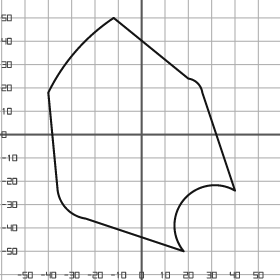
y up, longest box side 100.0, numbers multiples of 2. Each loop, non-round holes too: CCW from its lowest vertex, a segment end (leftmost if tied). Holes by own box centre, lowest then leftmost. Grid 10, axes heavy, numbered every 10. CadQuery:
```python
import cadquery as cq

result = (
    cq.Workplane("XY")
    .moveTo(18.0, -50.0)
    .threePointArc((18.0, -28.0), (40.0, -24.0))
    .lineTo(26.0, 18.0)
    .threePointArc((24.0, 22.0), (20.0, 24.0))
    .lineTo(-12.0, 50.0)
    .threePointArc((-28.0, 36.0), (-40.0, 18.0))
    .lineTo(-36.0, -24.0)
    .threePointArc((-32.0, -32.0), (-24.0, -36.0))
    .close()
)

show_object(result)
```